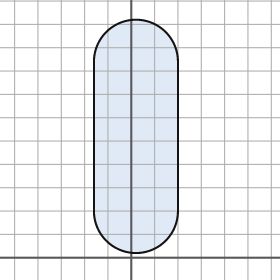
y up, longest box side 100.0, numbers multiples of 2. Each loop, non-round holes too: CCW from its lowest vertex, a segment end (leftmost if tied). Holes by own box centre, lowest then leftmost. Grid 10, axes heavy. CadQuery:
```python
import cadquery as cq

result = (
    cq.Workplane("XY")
    .moveTo(-16.0, 20.0)
    .threePointArc((2.0, 2.0), (20.0, 20.0))
    .lineTo(20.0, 84.0)
    .threePointArc((2.0, 102.0), (-16.0, 84.0))
    .close()
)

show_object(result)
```